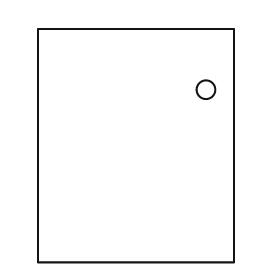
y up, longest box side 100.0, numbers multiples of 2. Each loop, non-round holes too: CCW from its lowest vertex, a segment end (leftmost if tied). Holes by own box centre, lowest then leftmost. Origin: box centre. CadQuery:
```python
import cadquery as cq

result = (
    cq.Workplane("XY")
    .moveTo(-42.0, -50.0)
    .lineTo(42.0, -50.0)
    .lineTo(42.0, 50.0)
    .lineTo(-42.0, 50.0)
    .close()
    .moveTo(30.0, 24.0)
    .circle(4.0)
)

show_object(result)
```